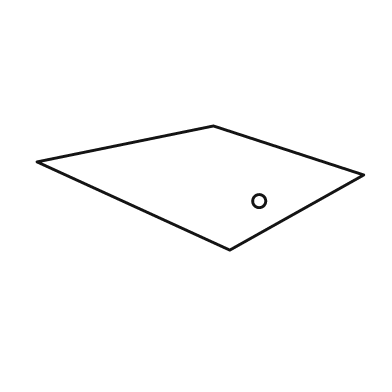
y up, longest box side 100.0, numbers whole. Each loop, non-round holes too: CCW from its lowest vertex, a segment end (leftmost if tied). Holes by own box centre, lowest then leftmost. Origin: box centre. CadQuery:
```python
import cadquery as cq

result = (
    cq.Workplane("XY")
    .moveTo(9.0, -19.0)
    .lineTo(50.0, 4.0)
    .lineTo(4.0, 19.0)
    .lineTo(-50.0, 8.0)
    .close()
    .moveTo(18.0, -4.0)
    .circle(2.0)
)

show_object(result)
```